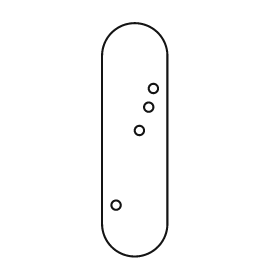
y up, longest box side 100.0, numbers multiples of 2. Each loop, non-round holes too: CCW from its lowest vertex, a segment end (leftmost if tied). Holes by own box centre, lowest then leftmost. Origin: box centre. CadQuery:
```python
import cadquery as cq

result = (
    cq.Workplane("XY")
    .moveTo(-14.0, -36.0)
    .threePointArc((0.0, -50.0), (14.0, -36.0))
    .lineTo(14.0, 36.0)
    .threePointArc((0.0, 50.0), (-14.0, 36.0))
    .close()
    .moveTo(-8.0, -28.0)
    .circle(2.0)
    .moveTo(2.0, 4.0)
    .circle(2.0)
    .moveTo(6.0, 14.0)
    .circle(2.0)
    .moveTo(8.0, 22.0)
    .circle(2.0)
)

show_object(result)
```